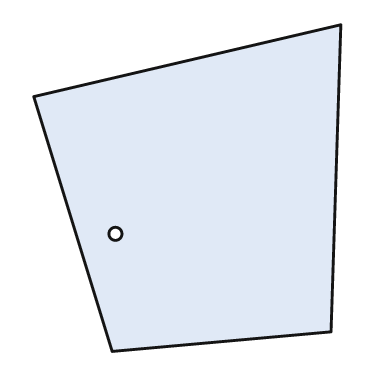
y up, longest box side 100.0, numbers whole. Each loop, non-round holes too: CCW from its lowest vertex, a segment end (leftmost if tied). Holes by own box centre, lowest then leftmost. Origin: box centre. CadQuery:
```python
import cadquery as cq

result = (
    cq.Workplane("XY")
    .moveTo(-23.0, -50.0)
    .lineTo(44.0, -44.0)
    .lineTo(47.0, 50.0)
    .lineTo(-47.0, 28.0)
    .close()
    .moveTo(-22.0, -14.0)
    .circle(2.0)
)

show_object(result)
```